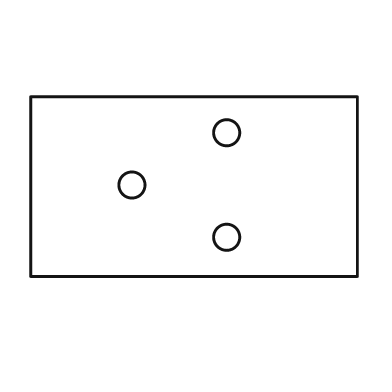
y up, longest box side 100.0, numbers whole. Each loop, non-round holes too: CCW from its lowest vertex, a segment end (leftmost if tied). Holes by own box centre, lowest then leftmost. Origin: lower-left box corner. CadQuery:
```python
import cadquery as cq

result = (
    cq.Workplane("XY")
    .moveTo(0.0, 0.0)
    .lineTo(100.0, 0.0)
    .lineTo(100.0, 55.0)
    .lineTo(0.0, 55.0)
    .close()
    .moveTo(60.0, 12.0)
    .circle(4.0)
    .moveTo(31.0, 28.0)
    .circle(4.0)
    .moveTo(60.0, 44.0)
    .circle(4.0)
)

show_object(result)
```